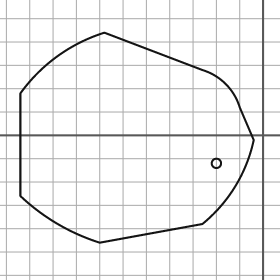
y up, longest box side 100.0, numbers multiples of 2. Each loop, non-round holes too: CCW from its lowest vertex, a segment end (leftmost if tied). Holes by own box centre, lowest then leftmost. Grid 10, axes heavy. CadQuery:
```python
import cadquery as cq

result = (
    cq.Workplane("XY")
    .moveTo(-70.0, -46.0)
    .lineTo(-26.0, -38.0)
    .threePointArc((-12.0, -22.0), (-4.0, -2.0))
    .lineTo(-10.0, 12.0)
    .threePointArc((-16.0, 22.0), (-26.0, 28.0))
    .lineTo(-68.0, 44.0)
    .threePointArc((-88.0, 34.0), (-104.0, 18.0))
    .lineTo(-104.0, -26.0)
    .threePointArc((-88.0, -38.0), (-70.0, -46.0))
    .close()
    .moveTo(-20.0, -12.0)
    .circle(2.0)
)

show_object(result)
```